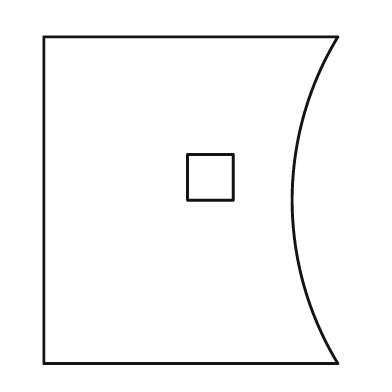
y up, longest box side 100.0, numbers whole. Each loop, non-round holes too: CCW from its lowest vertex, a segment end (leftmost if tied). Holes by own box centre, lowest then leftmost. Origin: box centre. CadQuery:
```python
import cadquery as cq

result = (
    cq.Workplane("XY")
    .moveTo(-45.0, -50.0)
    .lineTo(45.0, -50.0)
    .threePointArc((31.0, 0.0), (45.0, 50.0))
    .lineTo(-45.0, 50.0)
    .close()
    .moveTo(-1.0, 0.0)
    .lineTo(13.0, 0.0)
    .lineTo(13.0, 14.0)
    .lineTo(-1.0, 14.0)
    .close()
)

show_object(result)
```